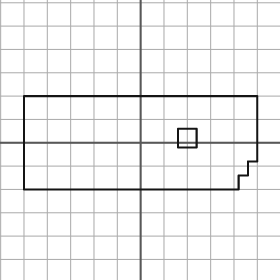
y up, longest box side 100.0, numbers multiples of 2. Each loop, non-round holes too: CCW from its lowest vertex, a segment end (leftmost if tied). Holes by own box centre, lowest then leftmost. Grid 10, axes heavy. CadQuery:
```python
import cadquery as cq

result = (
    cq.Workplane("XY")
    .moveTo(-50.0, -20.0)
    .lineTo(42.0, -20.0)
    .lineTo(42.0, -14.0)
    .lineTo(46.0, -14.0)
    .lineTo(46.0, -8.0)
    .lineTo(50.0, -8.0)
    .lineTo(50.0, 20.0)
    .lineTo(-50.0, 20.0)
    .close()
    .moveTo(16.0, -2.0)
    .lineTo(24.0, -2.0)
    .lineTo(24.0, 6.0)
    .lineTo(16.0, 6.0)
    .close()
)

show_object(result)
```